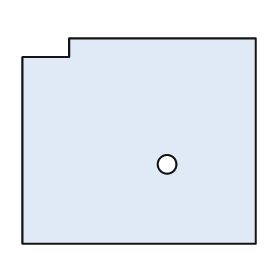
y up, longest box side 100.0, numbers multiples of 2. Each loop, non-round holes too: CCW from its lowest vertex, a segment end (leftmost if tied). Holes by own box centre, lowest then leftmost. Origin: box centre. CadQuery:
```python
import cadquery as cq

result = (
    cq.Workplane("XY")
    .moveTo(-50.0, -44.0)
    .lineTo(50.0, -44.0)
    .lineTo(50.0, 44.0)
    .lineTo(-30.0, 44.0)
    .lineTo(-30.0, 36.0)
    .lineTo(-50.0, 36.0)
    .close()
    .moveTo(12.0, -10.0)
    .circle(4.0)
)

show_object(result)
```